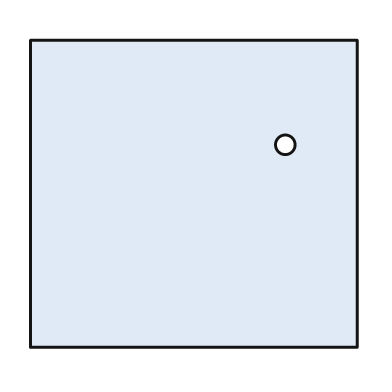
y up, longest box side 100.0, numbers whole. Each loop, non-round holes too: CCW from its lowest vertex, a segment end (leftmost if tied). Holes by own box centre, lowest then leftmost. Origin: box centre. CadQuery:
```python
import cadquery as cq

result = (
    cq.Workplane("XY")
    .moveTo(-50.0, -47.0)
    .lineTo(50.0, -47.0)
    .lineTo(50.0, 47.0)
    .lineTo(-50.0, 47.0)
    .close()
    .moveTo(28.0, 15.0)
    .circle(3.0)
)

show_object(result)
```